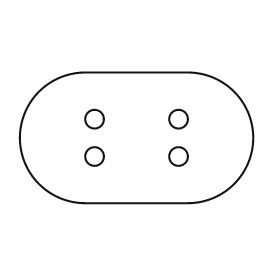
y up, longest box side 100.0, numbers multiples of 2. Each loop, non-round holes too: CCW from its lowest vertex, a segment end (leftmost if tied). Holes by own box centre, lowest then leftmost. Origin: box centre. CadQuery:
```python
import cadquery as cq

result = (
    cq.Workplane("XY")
    .moveTo(-22.0, -28.0)
    .lineTo(22.0, -28.0)
    .threePointArc((50.0, 0.0), (22.0, 28.0))
    .lineTo(-22.0, 28.0)
    .threePointArc((-50.0, 0.0), (-22.0, -28.0))
    .close()
    .moveTo(-18.0, -8.0)
    .circle(4.0)
    .moveTo(18.0, -8.0)
    .circle(4.0)
    .moveTo(-18.0, 8.0)
    .circle(4.0)
    .moveTo(18.0, 8.0)
    .circle(4.0)
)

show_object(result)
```